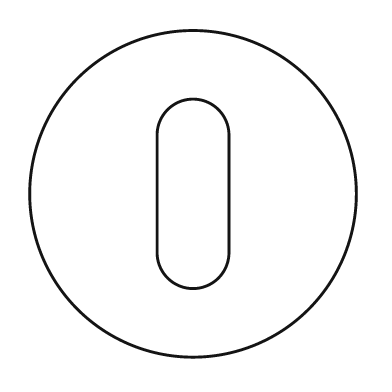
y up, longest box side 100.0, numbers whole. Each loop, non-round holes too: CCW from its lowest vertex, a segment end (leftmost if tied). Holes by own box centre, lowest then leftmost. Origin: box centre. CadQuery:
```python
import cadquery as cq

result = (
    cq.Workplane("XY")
    .moveTo(0.0, 0.0)
    .circle(50.0)
    .moveTo(-11.0, -18.0)
    .threePointArc((0.0, -29.0), (11.0, -18.0))
    .lineTo(11.0, 18.0)
    .threePointArc((0.0, 29.0), (-11.0, 18.0))
    .close()
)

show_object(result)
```